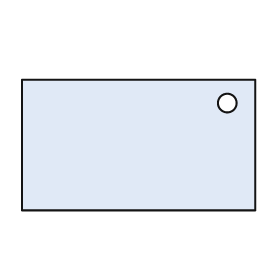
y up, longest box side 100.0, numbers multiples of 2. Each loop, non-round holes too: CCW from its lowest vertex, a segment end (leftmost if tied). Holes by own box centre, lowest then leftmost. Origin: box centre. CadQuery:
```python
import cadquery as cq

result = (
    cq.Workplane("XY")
    .moveTo(-50.0, -28.0)
    .lineTo(50.0, -28.0)
    .lineTo(50.0, 28.0)
    .lineTo(-50.0, 28.0)
    .close()
    .moveTo(38.0, 18.0)
    .circle(4.0)
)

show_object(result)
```